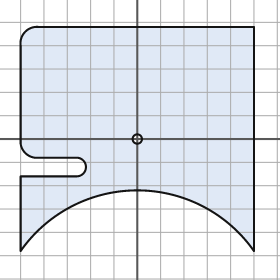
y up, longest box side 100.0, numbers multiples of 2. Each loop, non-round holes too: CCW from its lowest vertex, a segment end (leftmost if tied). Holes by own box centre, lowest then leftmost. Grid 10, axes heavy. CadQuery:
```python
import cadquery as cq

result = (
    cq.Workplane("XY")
    .moveTo(-50.0, -48.0)
    .threePointArc((0.0, -22.0), (50.0, -48.0))
    .lineTo(50.0, 48.0)
    .lineTo(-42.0, 48.0)
    .threePointArc((-48.0, 46.0), (-50.0, 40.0))
    .lineTo(-50.0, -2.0)
    .threePointArc((-48.0, -6.0), (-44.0, -8.0))
    .lineTo(-26.0, -8.0)
    .threePointArc((-22.0, -12.0), (-26.0, -16.0))
    .lineTo(-50.0, -16.0)
    .close()
    .moveTo(0.0, 0.0)
    .circle(2.0)
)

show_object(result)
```